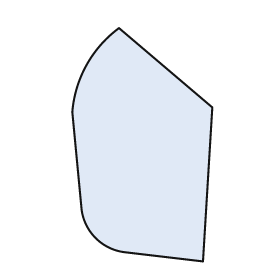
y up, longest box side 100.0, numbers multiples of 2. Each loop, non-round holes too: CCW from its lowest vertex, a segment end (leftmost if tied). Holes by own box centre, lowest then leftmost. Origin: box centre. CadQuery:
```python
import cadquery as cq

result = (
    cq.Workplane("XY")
    .moveTo(26.0, -50.0)
    .lineTo(30.0, 16.0)
    .lineTo(-10.0, 50.0)
    .threePointArc((-24.0, 34.0), (-30.0, 14.0))
    .lineTo(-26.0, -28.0)
    .threePointArc((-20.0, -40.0), (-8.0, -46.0))
    .close()
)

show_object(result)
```